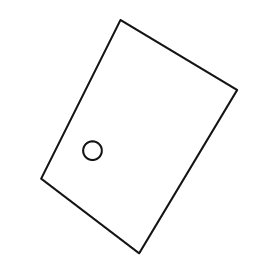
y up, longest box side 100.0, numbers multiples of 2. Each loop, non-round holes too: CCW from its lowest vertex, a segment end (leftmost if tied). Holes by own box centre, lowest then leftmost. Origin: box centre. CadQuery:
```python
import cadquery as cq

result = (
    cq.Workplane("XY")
    .moveTo(0.0, -50.0)
    .lineTo(42.0, 20.0)
    .lineTo(-8.0, 50.0)
    .lineTo(-42.0, -18.0)
    .close()
    .moveTo(-20.0, -6.0)
    .circle(4.0)
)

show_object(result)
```